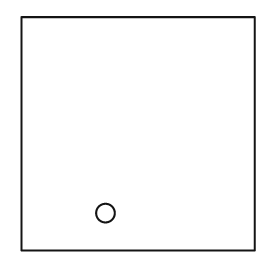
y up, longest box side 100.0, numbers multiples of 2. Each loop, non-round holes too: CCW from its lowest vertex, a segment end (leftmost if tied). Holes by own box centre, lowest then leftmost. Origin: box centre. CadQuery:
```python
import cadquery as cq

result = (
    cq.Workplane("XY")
    .moveTo(-50.0, -50.0)
    .lineTo(50.0, -50.0)
    .lineTo(50.0, 50.0)
    .lineTo(-50.0, 50.0)
    .close()
    .moveTo(-14.0, -34.0)
    .circle(4.0)
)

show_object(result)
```